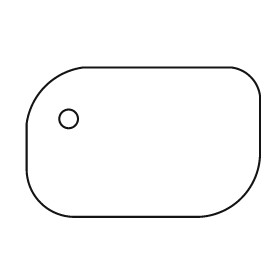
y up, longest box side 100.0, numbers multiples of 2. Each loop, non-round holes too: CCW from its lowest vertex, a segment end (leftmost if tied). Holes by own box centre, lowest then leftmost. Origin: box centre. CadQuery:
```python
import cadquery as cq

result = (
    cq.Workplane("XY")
    .moveTo(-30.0, -32.0)
    .lineTo(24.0, -32.0)
    .threePointArc((42.0, -24.0), (50.0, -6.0))
    .lineTo(50.0, 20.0)
    .threePointArc((46.0, 28.0), (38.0, 32.0))
    .lineTo(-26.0, 32.0)
    .threePointArc((-42.0, 24.0), (-50.0, 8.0))
    .lineTo(-50.0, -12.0)
    .threePointArc((-44.0, -26.0), (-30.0, -32.0))
    .close()
    .moveTo(-32.0, 10.0)
    .circle(4.0)
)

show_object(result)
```